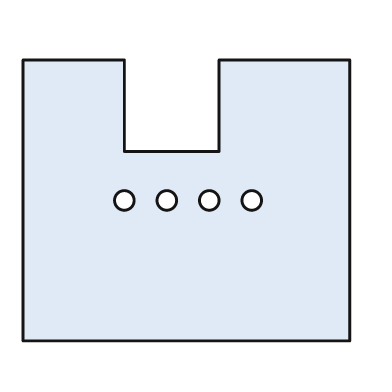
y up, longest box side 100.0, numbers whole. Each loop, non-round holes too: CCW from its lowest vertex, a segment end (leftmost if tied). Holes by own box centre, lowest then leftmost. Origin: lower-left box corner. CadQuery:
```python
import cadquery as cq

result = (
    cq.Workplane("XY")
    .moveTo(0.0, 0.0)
    .lineTo(100.0, 0.0)
    .lineTo(100.0, 86.0)
    .lineTo(60.0, 86.0)
    .lineTo(60.0, 58.0)
    .lineTo(31.0, 58.0)
    .lineTo(31.0, 86.0)
    .lineTo(0.0, 86.0)
    .close()
    .moveTo(31.0, 43.0)
    .circle(3.0)
    .moveTo(44.0, 43.0)
    .circle(3.0)
    .moveTo(57.0, 43.0)
    .circle(3.0)
    .moveTo(70.0, 43.0)
    .circle(3.0)
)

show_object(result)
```